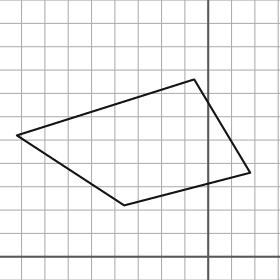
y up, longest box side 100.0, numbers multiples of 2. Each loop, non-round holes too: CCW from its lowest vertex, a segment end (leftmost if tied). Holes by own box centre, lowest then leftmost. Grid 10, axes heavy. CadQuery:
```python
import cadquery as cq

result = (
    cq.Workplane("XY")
    .moveTo(-36.0, 22.0)
    .lineTo(18.0, 36.0)
    .lineTo(-6.0, 76.0)
    .lineTo(-82.0, 52.0)
    .close()
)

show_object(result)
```